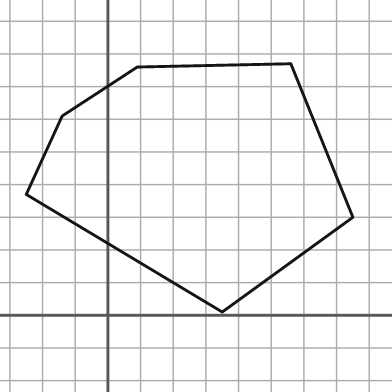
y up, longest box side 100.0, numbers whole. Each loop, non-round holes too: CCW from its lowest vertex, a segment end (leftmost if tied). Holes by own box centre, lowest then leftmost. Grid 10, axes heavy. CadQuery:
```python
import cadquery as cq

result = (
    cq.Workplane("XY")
    .moveTo(35.0, 1.0)
    .lineTo(75.0, 30.0)
    .lineTo(56.0, 77.0)
    .lineTo(9.0, 76.0)
    .lineTo(-14.0, 61.0)
    .lineTo(-25.0, 37.0)
    .close()
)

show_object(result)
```